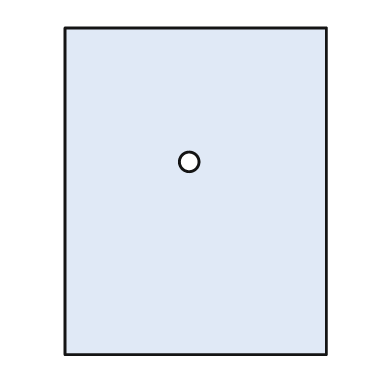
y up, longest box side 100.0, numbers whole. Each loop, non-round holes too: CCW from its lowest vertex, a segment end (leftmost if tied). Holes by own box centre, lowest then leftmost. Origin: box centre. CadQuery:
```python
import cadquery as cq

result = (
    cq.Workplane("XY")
    .moveTo(-40.0, -50.0)
    .lineTo(40.0, -50.0)
    .lineTo(40.0, 50.0)
    .lineTo(-40.0, 50.0)
    .close()
    .moveTo(-2.0, 9.0)
    .circle(3.0)
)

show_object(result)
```